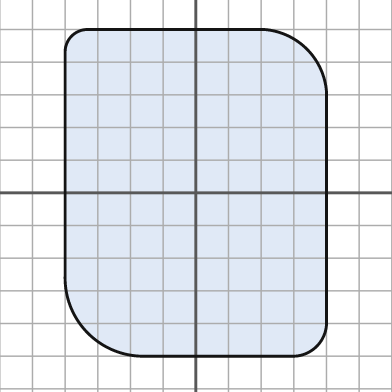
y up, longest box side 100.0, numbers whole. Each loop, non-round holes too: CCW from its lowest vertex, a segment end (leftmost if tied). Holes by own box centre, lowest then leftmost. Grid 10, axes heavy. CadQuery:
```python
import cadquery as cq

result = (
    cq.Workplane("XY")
    .moveTo(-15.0, -50.0)
    .lineTo(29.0, -50.0)
    .threePointArc((37.0, -47.0), (40.0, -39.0))
    .lineTo(40.0, 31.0)
    .threePointArc((34.0, 44.0), (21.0, 50.0))
    .lineTo(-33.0, 50.0)
    .threePointArc((-38.0, 48.0), (-40.0, 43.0))
    .lineTo(-40.0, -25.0)
    .threePointArc((-33.0, -43.0), (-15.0, -50.0))
    .close()
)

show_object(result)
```